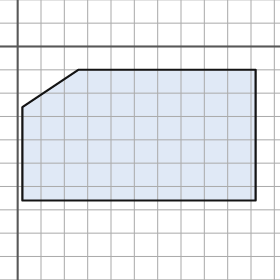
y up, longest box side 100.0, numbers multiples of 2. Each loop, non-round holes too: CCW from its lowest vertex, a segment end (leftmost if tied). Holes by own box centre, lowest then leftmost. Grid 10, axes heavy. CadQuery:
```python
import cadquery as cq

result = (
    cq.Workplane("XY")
    .moveTo(2.0, -66.0)
    .lineTo(102.0, -66.0)
    .lineTo(102.0, -10.0)
    .lineTo(26.0, -10.0)
    .lineTo(2.0, -26.0)
    .close()
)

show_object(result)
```